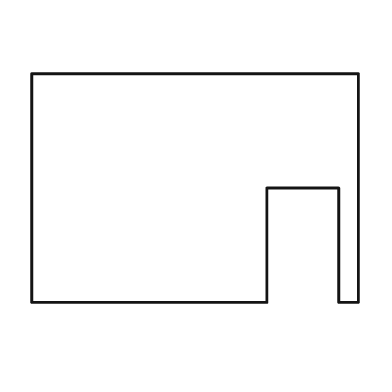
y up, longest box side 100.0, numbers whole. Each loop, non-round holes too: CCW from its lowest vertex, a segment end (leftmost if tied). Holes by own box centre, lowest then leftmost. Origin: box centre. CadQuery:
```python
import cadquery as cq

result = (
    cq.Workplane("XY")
    .moveTo(-50.0, -35.0)
    .lineTo(22.0, -35.0)
    .lineTo(22.0, 0.0)
    .lineTo(44.0, 0.0)
    .lineTo(44.0, -35.0)
    .lineTo(50.0, -35.0)
    .lineTo(50.0, 35.0)
    .lineTo(-50.0, 35.0)
    .close()
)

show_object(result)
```